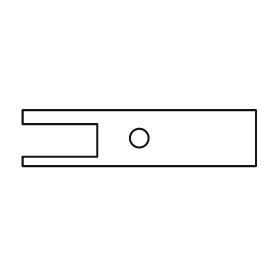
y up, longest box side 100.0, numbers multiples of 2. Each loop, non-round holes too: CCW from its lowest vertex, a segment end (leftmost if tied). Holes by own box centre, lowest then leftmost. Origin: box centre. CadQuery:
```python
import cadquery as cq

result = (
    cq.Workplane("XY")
    .moveTo(-50.0, -12.0)
    .lineTo(50.0, -12.0)
    .lineTo(50.0, 12.0)
    .lineTo(-50.0, 12.0)
    .lineTo(-50.0, 6.0)
    .lineTo(-18.0, 6.0)
    .lineTo(-18.0, -8.0)
    .lineTo(-50.0, -8.0)
    .close()
    .moveTo(0.0, 0.0)
    .circle(4.0)
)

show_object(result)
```